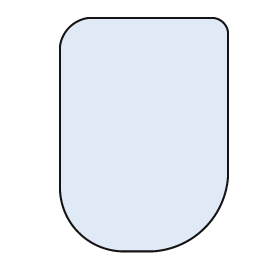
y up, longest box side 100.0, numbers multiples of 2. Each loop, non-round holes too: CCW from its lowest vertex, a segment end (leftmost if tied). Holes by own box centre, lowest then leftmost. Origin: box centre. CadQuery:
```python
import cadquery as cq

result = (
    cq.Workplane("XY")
    .moveTo(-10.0, -50.0)
    .lineTo(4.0, -50.0)
    .threePointArc((26.0, -40.0), (36.0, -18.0))
    .lineTo(36.0, 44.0)
    .threePointArc((34.0, 48.0), (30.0, 50.0))
    .lineTo(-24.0, 50.0)
    .threePointArc((-32.0, 46.0), (-36.0, 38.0))
    .lineTo(-36.0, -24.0)
    .threePointArc((-28.0, -42.0), (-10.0, -50.0))
    .close()
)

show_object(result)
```